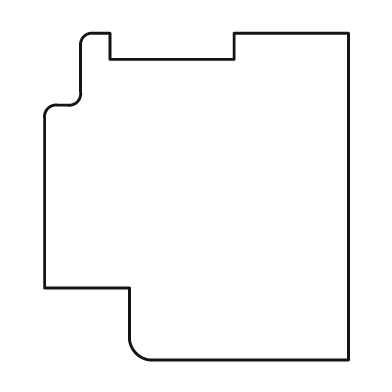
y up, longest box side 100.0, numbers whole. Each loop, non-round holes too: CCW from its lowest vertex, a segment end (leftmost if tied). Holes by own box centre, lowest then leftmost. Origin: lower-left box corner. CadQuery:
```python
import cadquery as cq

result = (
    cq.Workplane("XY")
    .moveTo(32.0, 0.0)
    .lineTo(93.0, 0.0)
    .lineTo(93.0, 100.0)
    .lineTo(58.0, 100.0)
    .lineTo(58.0, 92.0)
    .lineTo(20.0, 92.0)
    .lineTo(20.0, 100.0)
    .lineTo(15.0, 100.0)
    .threePointArc((12.0, 99.0), (11.0, 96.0))
    .lineTo(11.0, 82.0)
    .threePointArc((10.0, 79.0), (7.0, 78.0))
    .lineTo(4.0, 78.0)
    .threePointArc((1.0, 77.0), (0.0, 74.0))
    .lineTo(0.0, 22.0)
    .lineTo(26.0, 22.0)
    .lineTo(26.0, 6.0)
    .threePointArc((28.0, 2.0), (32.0, 0.0))
    .close()
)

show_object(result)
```